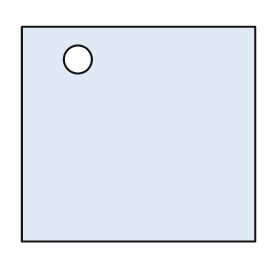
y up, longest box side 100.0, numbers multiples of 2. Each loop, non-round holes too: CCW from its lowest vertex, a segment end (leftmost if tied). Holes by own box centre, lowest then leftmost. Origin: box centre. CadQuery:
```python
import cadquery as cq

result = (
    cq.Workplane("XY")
    .moveTo(-50.0, -46.0)
    .lineTo(50.0, -46.0)
    .lineTo(50.0, 46.0)
    .lineTo(-50.0, 46.0)
    .close()
    .moveTo(-26.0, 32.0)
    .circle(6.0)
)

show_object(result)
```